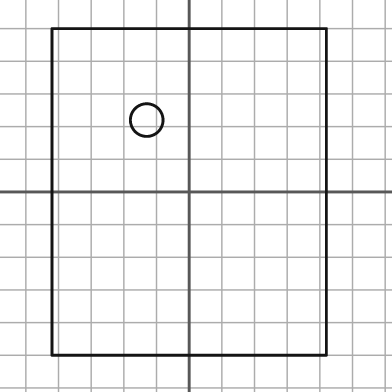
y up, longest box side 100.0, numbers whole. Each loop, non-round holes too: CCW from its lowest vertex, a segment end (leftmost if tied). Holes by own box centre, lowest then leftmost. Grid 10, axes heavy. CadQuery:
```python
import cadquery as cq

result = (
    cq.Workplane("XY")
    .moveTo(-42.0, -50.0)
    .lineTo(42.0, -50.0)
    .lineTo(42.0, 50.0)
    .lineTo(-42.0, 50.0)
    .close()
    .moveTo(-13.0, 22.0)
    .circle(5.0)
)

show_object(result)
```